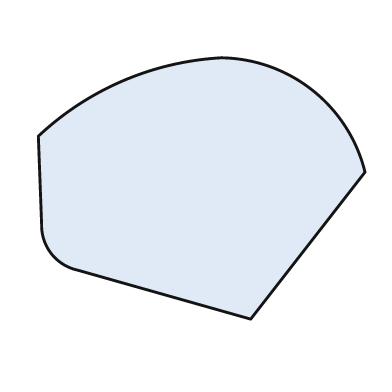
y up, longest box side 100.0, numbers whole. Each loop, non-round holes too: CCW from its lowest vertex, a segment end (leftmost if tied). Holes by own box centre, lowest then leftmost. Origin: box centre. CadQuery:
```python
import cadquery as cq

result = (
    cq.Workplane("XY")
    .moveTo(15.0, -40.0)
    .lineTo(50.0, 5.0)
    .threePointArc((34.0, 30.0), (6.0, 40.0))
    .threePointArc((-24.0, 33.0), (-50.0, 16.0))
    .lineTo(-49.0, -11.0)
    .threePointArc((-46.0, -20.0), (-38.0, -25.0))
    .close()
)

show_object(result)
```